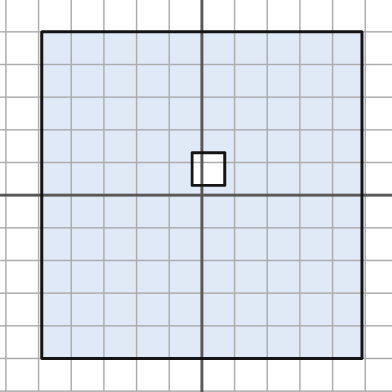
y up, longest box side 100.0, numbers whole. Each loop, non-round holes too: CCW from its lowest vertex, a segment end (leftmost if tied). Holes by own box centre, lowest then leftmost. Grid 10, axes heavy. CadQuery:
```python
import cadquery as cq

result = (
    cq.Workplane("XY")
    .moveTo(-49.0, -50.0)
    .lineTo(49.0, -50.0)
    .lineTo(49.0, 50.0)
    .lineTo(-49.0, 50.0)
    .close()
    .moveTo(-3.0, 3.0)
    .lineTo(7.0, 3.0)
    .lineTo(7.0, 13.0)
    .lineTo(-3.0, 13.0)
    .close()
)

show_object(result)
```